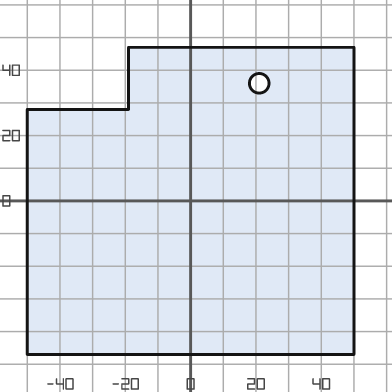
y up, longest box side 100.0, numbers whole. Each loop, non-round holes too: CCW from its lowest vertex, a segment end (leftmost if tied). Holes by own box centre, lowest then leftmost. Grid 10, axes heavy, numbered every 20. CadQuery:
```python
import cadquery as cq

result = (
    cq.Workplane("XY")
    .moveTo(-50.0, -47.0)
    .lineTo(50.0, -47.0)
    .lineTo(50.0, 47.0)
    .lineTo(-19.0, 47.0)
    .lineTo(-19.0, 28.0)
    .lineTo(-50.0, 28.0)
    .close()
    .moveTo(21.0, 36.0)
    .circle(3.0)
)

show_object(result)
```